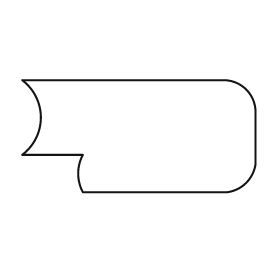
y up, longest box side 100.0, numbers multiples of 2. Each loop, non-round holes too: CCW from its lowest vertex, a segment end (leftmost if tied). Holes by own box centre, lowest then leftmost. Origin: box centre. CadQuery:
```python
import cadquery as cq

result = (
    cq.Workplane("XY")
    .moveTo(-24.0, -24.0)
    .lineTo(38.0, -24.0)
    .threePointArc((46.0, -20.0), (50.0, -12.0))
    .lineTo(50.0, 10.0)
    .threePointArc((46.0, 20.0), (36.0, 24.0))
    .lineTo(-50.0, 24.0)
    .threePointArc((-42.0, 8.0), (-50.0, -8.0))
    .lineTo(-24.0, -8.0)
    .threePointArc((-26.0, -16.0), (-24.0, -24.0))
    .close()
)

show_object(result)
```